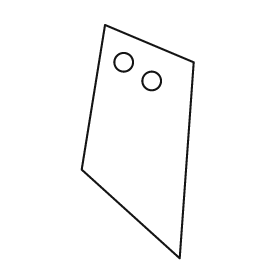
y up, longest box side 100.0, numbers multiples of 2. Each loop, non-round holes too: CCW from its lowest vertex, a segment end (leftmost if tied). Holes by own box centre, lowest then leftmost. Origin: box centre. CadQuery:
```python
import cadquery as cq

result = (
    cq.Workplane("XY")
    .moveTo(18.0, -50.0)
    .lineTo(24.0, 34.0)
    .lineTo(-14.0, 50.0)
    .lineTo(-24.0, -12.0)
    .close()
    .moveTo(6.0, 26.0)
    .circle(4.0)
    .moveTo(-6.0, 34.0)
    .circle(4.0)
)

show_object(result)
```